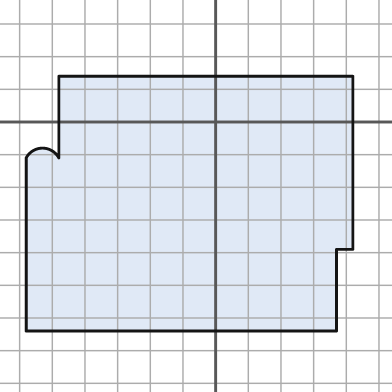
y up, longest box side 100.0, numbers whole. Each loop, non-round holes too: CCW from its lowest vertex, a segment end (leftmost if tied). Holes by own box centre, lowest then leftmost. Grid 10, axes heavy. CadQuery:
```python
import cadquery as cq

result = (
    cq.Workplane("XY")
    .moveTo(-58.0, -64.0)
    .lineTo(37.0, -64.0)
    .lineTo(37.0, -39.0)
    .lineTo(42.0, -39.0)
    .lineTo(42.0, 14.0)
    .lineTo(-48.0, 14.0)
    .lineTo(-48.0, -11.0)
    .threePointArc((-53.0, -8.0), (-58.0, -11.0))
    .close()
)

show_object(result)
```